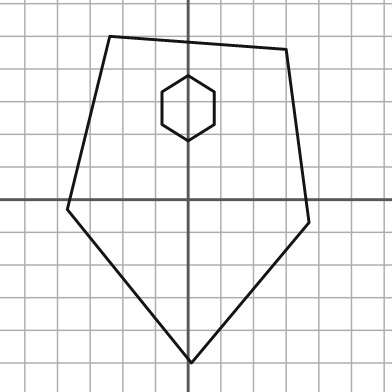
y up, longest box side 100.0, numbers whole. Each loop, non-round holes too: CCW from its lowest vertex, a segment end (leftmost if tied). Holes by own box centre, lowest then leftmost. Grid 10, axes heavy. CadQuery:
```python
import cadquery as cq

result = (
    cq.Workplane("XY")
    .moveTo(1.0, -50.0)
    .lineTo(37.0, -7.0)
    .lineTo(30.0, 46.0)
    .lineTo(-24.0, 50.0)
    .lineTo(-37.0, -3.0)
    .close()
    .moveTo(0.0, 18.0)
    .lineTo(8.0, 23.0)
    .lineTo(8.0, 33.0)
    .lineTo(0.0, 38.0)
    .lineTo(-8.0, 33.0)
    .lineTo(-8.0, 23.0)
    .close()
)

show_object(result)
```